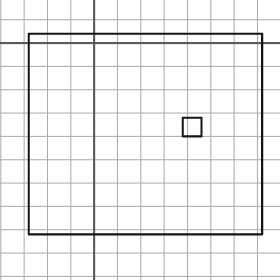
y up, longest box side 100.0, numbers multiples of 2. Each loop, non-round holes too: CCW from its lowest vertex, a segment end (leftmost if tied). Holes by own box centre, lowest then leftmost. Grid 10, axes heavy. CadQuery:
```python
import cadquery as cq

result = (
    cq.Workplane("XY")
    .moveTo(-28.0, -82.0)
    .lineTo(72.0, -82.0)
    .lineTo(72.0, 4.0)
    .lineTo(-28.0, 4.0)
    .close()
    .moveTo(38.0, -40.0)
    .lineTo(46.0, -40.0)
    .lineTo(46.0, -32.0)
    .lineTo(38.0, -32.0)
    .close()
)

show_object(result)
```